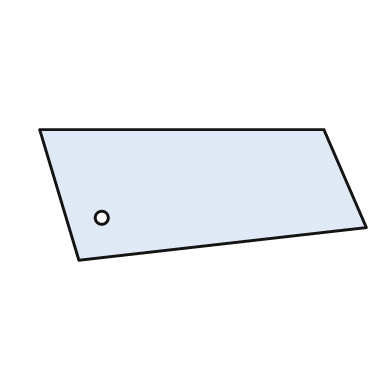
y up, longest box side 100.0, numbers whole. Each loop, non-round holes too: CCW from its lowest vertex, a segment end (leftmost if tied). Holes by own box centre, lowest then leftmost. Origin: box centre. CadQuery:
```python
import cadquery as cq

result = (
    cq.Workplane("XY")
    .moveTo(-38.0, -20.0)
    .lineTo(50.0, -10.0)
    .lineTo(37.0, 20.0)
    .lineTo(-50.0, 20.0)
    .close()
    .moveTo(-31.0, -7.0)
    .circle(2.0)
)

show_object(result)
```